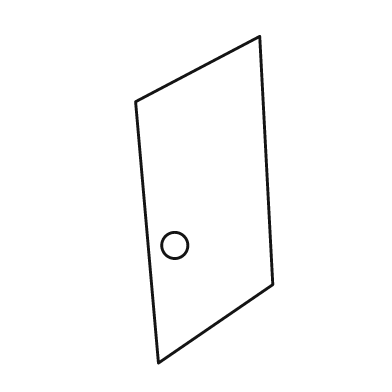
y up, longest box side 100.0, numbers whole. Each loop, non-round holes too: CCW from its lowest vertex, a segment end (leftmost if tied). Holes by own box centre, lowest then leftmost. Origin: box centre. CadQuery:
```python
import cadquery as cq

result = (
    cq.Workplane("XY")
    .moveTo(-14.0, -50.0)
    .lineTo(21.0, -26.0)
    .lineTo(17.0, 50.0)
    .lineTo(-21.0, 30.0)
    .close()
    .moveTo(-9.0, -14.0)
    .circle(4.0)
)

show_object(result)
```